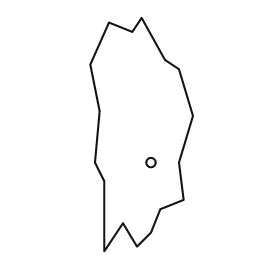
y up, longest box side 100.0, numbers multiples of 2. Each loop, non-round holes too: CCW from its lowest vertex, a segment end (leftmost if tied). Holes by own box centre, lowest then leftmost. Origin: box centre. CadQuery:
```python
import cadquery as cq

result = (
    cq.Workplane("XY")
    .moveTo(-16.0, -50.0)
    .lineTo(-8.0, -38.0)
    .lineTo(-2.0, -48.0)
    .lineTo(4.0, -42.0)
    .lineTo(8.0, -32.0)
    .lineTo(18.0, -28.0)
    .lineTo(16.0, -12.0)
    .lineTo(22.0, 8.0)
    .lineTo(16.0, 28.0)
    .lineTo(10.0, 32.0)
    .lineTo(0.0, 50.0)
    .lineTo(-4.0, 44.0)
    .lineTo(-14.0, 48.0)
    .lineTo(-22.0, 30.0)
    .lineTo(-18.0, 10.0)
    .lineTo(-20.0, -12.0)
    .lineTo(-16.0, -20.0)
    .close()
    .moveTo(4.0, -12.0)
    .circle(2.0)
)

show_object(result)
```